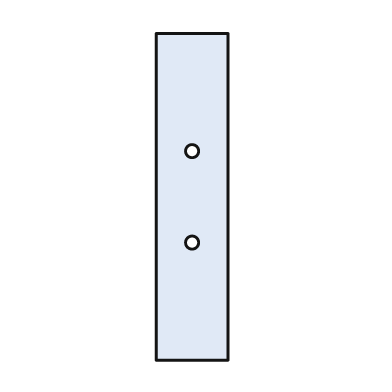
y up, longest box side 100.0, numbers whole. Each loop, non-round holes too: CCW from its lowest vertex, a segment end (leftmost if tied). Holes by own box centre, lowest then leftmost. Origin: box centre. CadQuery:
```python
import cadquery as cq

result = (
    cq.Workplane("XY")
    .moveTo(-11.0, -50.0)
    .lineTo(11.0, -50.0)
    .lineTo(11.0, 50.0)
    .lineTo(-11.0, 50.0)
    .close()
    .moveTo(0.0, -14.0)
    .circle(2.0)
    .moveTo(0.0, 14.0)
    .circle(2.0)
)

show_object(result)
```